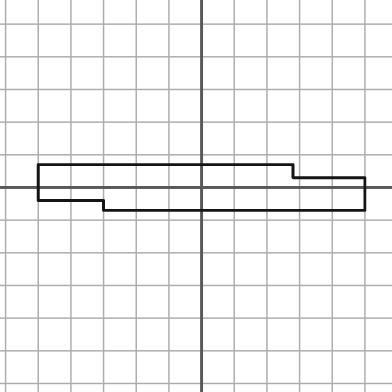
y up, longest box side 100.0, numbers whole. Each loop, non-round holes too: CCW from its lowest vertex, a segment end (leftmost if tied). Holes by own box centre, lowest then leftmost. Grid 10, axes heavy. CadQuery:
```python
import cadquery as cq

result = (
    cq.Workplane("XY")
    .moveTo(-30.0, -7.0)
    .lineTo(50.0, -7.0)
    .lineTo(50.0, 3.0)
    .lineTo(28.0, 3.0)
    .lineTo(28.0, 7.0)
    .lineTo(-50.0, 7.0)
    .lineTo(-50.0, -4.0)
    .lineTo(-30.0, -4.0)
    .close()
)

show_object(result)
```